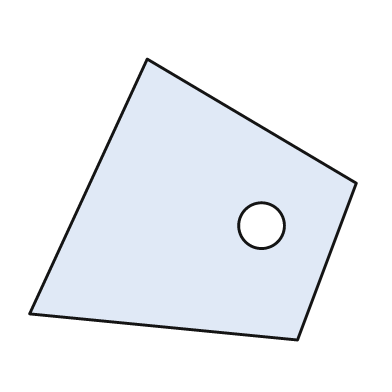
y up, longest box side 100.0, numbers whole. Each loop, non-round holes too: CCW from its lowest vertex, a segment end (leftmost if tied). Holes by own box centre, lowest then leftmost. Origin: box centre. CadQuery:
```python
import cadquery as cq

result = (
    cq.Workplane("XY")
    .moveTo(32.0, -43.0)
    .lineTo(50.0, 5.0)
    .lineTo(-14.0, 43.0)
    .lineTo(-50.0, -35.0)
    .close()
    .moveTo(21.0, -8.0)
    .circle(7.0)
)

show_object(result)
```